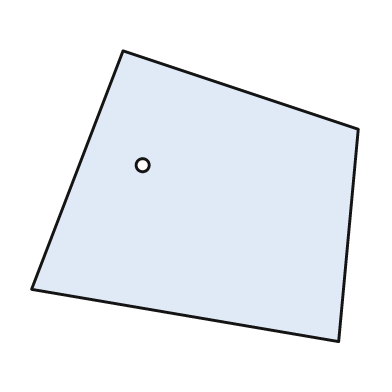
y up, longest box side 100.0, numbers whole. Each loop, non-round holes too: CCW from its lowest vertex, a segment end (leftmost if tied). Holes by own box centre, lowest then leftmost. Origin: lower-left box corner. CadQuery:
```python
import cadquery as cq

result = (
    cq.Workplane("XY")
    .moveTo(94.0, 0.0)
    .lineTo(100.0, 65.0)
    .lineTo(28.0, 89.0)
    .lineTo(0.0, 16.0)
    .close()
    .moveTo(34.0, 54.0)
    .circle(2.0)
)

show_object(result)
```